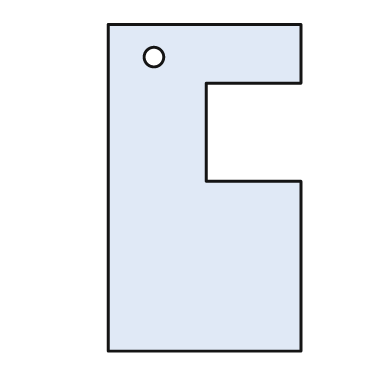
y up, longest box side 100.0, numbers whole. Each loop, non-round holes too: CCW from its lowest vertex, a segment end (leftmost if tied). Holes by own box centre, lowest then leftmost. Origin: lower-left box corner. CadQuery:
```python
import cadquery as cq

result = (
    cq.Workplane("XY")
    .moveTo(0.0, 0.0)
    .lineTo(59.0, 0.0)
    .lineTo(59.0, 52.0)
    .lineTo(30.0, 52.0)
    .lineTo(30.0, 82.0)
    .lineTo(59.0, 82.0)
    .lineTo(59.0, 100.0)
    .lineTo(0.0, 100.0)
    .close()
    .moveTo(14.0, 90.0)
    .circle(3.0)
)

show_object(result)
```